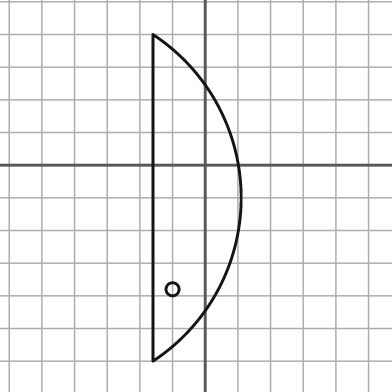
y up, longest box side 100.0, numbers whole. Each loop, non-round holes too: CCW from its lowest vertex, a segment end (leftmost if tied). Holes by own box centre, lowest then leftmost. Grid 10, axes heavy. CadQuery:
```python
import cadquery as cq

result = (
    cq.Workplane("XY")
    .moveTo(-16.0, -60.0)
    .threePointArc((11.0, -10.0), (-16.0, 40.0))
    .close()
    .moveTo(-10.0, -38.0)
    .circle(2.0)
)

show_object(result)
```